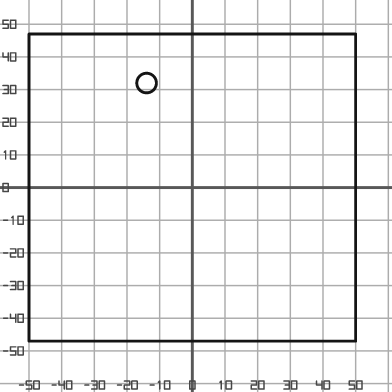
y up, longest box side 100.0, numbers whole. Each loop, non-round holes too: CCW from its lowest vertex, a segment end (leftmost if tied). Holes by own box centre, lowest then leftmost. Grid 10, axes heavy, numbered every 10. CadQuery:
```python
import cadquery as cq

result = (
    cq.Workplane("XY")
    .moveTo(-50.0, -47.0)
    .lineTo(50.0, -47.0)
    .lineTo(50.0, 47.0)
    .lineTo(-50.0, 47.0)
    .close()
    .moveTo(-14.0, 32.0)
    .circle(3.0)
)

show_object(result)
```